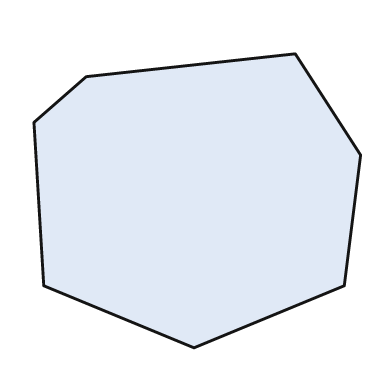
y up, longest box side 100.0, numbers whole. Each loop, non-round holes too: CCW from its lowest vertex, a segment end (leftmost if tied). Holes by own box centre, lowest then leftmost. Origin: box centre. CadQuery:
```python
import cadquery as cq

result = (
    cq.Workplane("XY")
    .moveTo(-1.0, -45.0)
    .lineTo(45.0, -26.0)
    .lineTo(50.0, 14.0)
    .lineTo(30.0, 45.0)
    .lineTo(-34.0, 38.0)
    .lineTo(-50.0, 24.0)
    .lineTo(-47.0, -26.0)
    .close()
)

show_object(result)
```